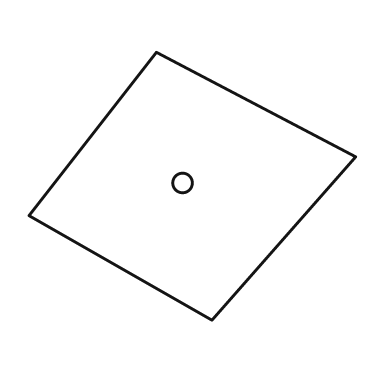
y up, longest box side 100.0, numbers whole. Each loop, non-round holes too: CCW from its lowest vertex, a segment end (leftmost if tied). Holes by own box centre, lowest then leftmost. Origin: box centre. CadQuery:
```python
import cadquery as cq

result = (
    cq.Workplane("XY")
    .moveTo(6.0, -41.0)
    .lineTo(50.0, 9.0)
    .lineTo(-11.0, 41.0)
    .lineTo(-50.0, -9.0)
    .close()
    .moveTo(-3.0, 1.0)
    .circle(3.0)
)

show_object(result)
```